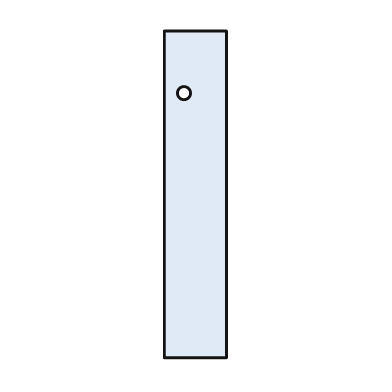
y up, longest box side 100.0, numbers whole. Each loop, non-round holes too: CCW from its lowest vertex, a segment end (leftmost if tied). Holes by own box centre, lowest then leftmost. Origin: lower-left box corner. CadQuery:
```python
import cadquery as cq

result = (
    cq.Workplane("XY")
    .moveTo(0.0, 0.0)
    .lineTo(19.0, 0.0)
    .lineTo(19.0, 100.0)
    .lineTo(0.0, 100.0)
    .close()
    .moveTo(6.0, 81.0)
    .circle(2.0)
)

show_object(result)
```